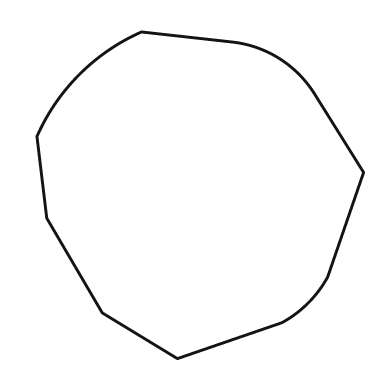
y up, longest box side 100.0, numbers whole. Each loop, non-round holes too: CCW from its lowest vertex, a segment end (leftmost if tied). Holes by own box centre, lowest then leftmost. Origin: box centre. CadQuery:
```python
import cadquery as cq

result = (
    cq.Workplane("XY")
    .moveTo(-7.0, -50.0)
    .lineTo(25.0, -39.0)
    .threePointArc((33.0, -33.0), (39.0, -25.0))
    .lineTo(50.0, 7.0)
    .lineTo(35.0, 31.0)
    .threePointArc((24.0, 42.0), (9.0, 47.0))
    .lineTo(-18.0, 50.0)
    .threePointArc((-37.0, 37.0), (-50.0, 18.0))
    .lineTo(-47.0, -7.0)
    .lineTo(-30.0, -36.0)
    .close()
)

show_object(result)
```